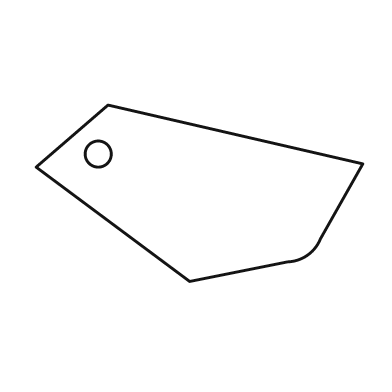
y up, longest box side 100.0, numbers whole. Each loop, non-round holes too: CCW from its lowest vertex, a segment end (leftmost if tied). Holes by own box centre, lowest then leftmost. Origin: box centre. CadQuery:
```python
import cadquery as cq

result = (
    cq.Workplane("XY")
    .moveTo(-3.0, -27.0)
    .lineTo(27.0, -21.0)
    .threePointArc((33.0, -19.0), (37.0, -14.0))
    .lineTo(50.0, 9.0)
    .lineTo(-28.0, 27.0)
    .lineTo(-50.0, 8.0)
    .close()
    .moveTo(-31.0, 12.0)
    .circle(4.0)
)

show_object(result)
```